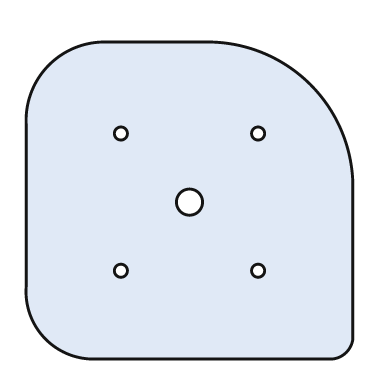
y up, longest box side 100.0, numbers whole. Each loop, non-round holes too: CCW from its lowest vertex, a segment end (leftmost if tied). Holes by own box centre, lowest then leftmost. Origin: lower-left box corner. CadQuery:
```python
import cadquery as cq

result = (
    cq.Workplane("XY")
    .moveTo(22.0, 0.0)
    .lineTo(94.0, 0.0)
    .threePointArc((98.0, 2.0), (100.0, 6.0))
    .lineTo(100.0, 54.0)
    .threePointArc((87.0, 84.0), (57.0, 97.0))
    .lineTo(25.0, 97.0)
    .threePointArc((7.0, 90.0), (0.0, 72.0))
    .lineTo(0.0, 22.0)
    .threePointArc((6.0, 6.0), (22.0, 0.0))
    .close()
    .moveTo(29.0, 27.0)
    .circle(2.0)
    .moveTo(71.0, 27.0)
    .circle(2.0)
    .moveTo(50.0, 48.0)
    .circle(4.0)
    .moveTo(29.0, 69.0)
    .circle(2.0)
    .moveTo(71.0, 69.0)
    .circle(2.0)
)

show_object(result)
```